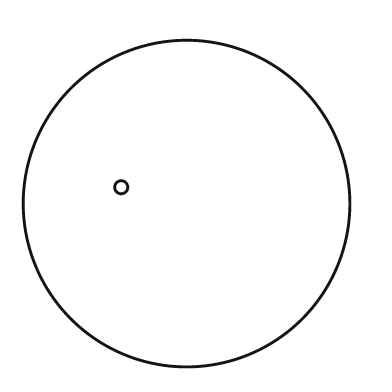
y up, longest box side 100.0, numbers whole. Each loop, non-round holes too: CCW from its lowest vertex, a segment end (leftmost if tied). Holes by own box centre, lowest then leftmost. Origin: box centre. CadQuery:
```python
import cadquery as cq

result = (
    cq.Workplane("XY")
    .moveTo(0.0, 0.0)
    .circle(50.0)
    .moveTo(-20.0, 5.0)
    .circle(2.0)
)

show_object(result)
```